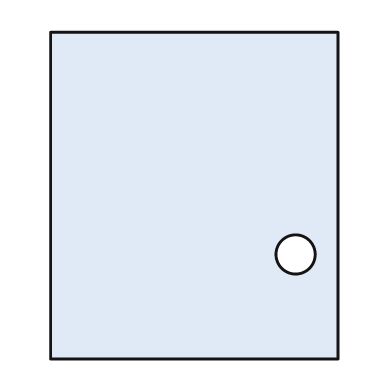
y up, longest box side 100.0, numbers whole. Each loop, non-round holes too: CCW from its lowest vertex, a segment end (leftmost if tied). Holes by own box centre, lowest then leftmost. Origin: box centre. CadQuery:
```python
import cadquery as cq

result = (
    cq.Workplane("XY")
    .moveTo(-44.0, -50.0)
    .lineTo(44.0, -50.0)
    .lineTo(44.0, 50.0)
    .lineTo(-44.0, 50.0)
    .close()
    .moveTo(31.0, -18.0)
    .circle(6.0)
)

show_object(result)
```